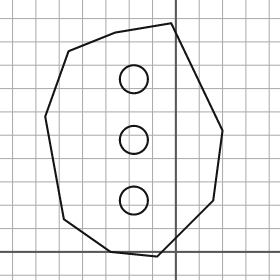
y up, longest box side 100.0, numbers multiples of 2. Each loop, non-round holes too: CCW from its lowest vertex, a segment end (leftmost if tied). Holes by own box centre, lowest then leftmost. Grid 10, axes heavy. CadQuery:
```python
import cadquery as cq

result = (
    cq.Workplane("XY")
    .moveTo(-8.0, -2.0)
    .lineTo(16.0, 22.0)
    .lineTo(20.0, 52.0)
    .lineTo(-2.0, 98.0)
    .lineTo(-26.0, 94.0)
    .lineTo(-46.0, 86.0)
    .lineTo(-56.0, 58.0)
    .lineTo(-48.0, 14.0)
    .lineTo(-28.0, 0.0)
    .close()
    .moveTo(-18.0, 22.0)
    .circle(6.0)
    .moveTo(-18.0, 48.0)
    .circle(6.0)
    .moveTo(-18.0, 74.0)
    .circle(6.0)
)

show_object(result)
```